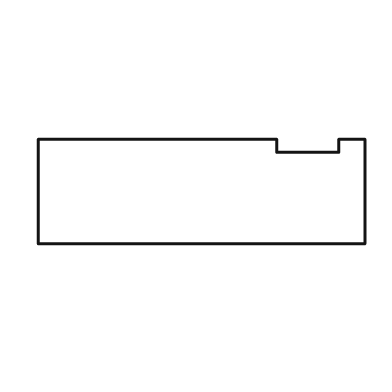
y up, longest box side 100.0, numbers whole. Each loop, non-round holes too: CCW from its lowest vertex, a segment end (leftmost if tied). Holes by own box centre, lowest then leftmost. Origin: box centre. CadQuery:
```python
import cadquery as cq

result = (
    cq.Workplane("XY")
    .moveTo(-50.0, -16.0)
    .lineTo(50.0, -16.0)
    .lineTo(50.0, 16.0)
    .lineTo(42.0, 16.0)
    .lineTo(42.0, 12.0)
    .lineTo(23.0, 12.0)
    .lineTo(23.0, 16.0)
    .lineTo(-50.0, 16.0)
    .close()
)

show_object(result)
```